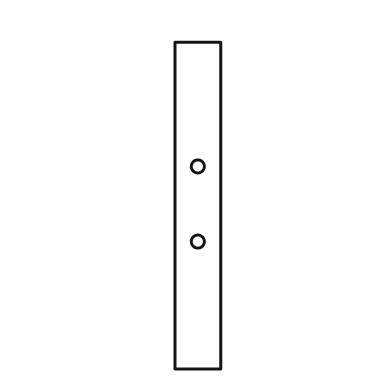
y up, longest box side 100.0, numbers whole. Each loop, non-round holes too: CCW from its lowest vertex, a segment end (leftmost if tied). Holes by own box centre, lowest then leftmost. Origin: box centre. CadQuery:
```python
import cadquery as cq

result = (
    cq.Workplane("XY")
    .moveTo(-7.0, -50.0)
    .lineTo(7.0, -50.0)
    .lineTo(7.0, 50.0)
    .lineTo(-7.0, 50.0)
    .close()
    .moveTo(0.0, -11.0)
    .circle(2.0)
    .moveTo(0.0, 12.0)
    .circle(2.0)
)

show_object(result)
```